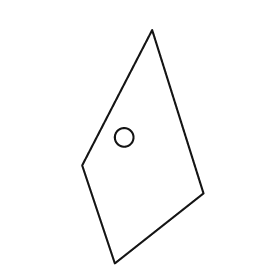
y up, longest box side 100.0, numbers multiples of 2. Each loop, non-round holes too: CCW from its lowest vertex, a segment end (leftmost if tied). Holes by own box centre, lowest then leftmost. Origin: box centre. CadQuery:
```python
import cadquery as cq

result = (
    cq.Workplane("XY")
    .moveTo(-12.0, -50.0)
    .lineTo(26.0, -20.0)
    .lineTo(4.0, 50.0)
    .lineTo(-26.0, -8.0)
    .close()
    .moveTo(-8.0, 4.0)
    .circle(4.0)
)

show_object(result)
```